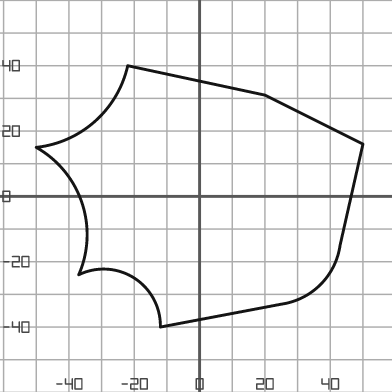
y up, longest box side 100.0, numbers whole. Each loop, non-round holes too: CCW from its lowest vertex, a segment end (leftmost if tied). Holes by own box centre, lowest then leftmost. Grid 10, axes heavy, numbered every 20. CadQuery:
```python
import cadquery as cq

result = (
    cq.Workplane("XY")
    .moveTo(-12.0, -40.0)
    .lineTo(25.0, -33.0)
    .threePointArc((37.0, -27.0), (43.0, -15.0))
    .lineTo(50.0, 16.0)
    .lineTo(20.0, 31.0)
    .lineTo(-22.0, 40.0)
    .threePointArc((-32.0, 23.0), (-50.0, 15.0))
    .threePointArc((-36.0, -2.0), (-37.0, -24.0))
    .threePointArc((-20.0, -25.0), (-12.0, -40.0))
    .close()
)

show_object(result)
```